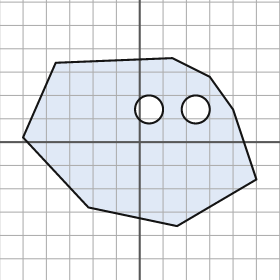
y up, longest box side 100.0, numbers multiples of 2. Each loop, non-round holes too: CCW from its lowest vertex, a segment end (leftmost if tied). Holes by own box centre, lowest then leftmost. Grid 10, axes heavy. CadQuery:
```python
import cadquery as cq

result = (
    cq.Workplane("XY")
    .moveTo(16.0, -36.0)
    .lineTo(50.0, -16.0)
    .lineTo(40.0, 14.0)
    .lineTo(30.0, 28.0)
    .lineTo(14.0, 36.0)
    .lineTo(-36.0, 34.0)
    .lineTo(-50.0, 2.0)
    .lineTo(-22.0, -28.0)
    .close()
    .moveTo(4.0, 14.0)
    .circle(6.0)
    .moveTo(24.0, 14.0)
    .circle(6.0)
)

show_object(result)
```